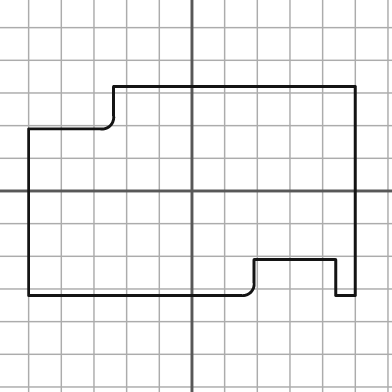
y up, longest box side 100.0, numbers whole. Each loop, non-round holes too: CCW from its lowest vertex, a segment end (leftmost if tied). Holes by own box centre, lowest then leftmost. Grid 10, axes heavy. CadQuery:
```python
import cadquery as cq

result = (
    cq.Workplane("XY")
    .moveTo(-50.0, -32.0)
    .lineTo(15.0, -32.0)
    .threePointArc((18.0, -31.0), (19.0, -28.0))
    .lineTo(19.0, -21.0)
    .lineTo(44.0, -21.0)
    .lineTo(44.0, -32.0)
    .lineTo(50.0, -32.0)
    .lineTo(50.0, 32.0)
    .lineTo(-24.0, 32.0)
    .lineTo(-24.0, 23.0)
    .threePointArc((-25.0, 20.0), (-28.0, 19.0))
    .lineTo(-50.0, 19.0)
    .close()
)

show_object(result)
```